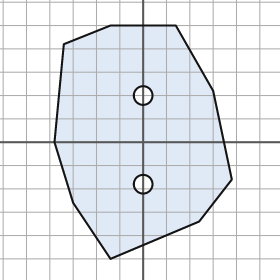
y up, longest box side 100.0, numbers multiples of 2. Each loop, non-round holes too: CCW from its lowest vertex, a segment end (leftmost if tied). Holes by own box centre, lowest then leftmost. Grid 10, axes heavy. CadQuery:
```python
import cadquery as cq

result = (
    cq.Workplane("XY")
    .moveTo(-14.0, -50.0)
    .lineTo(24.0, -34.0)
    .lineTo(38.0, -16.0)
    .lineTo(30.0, 22.0)
    .lineTo(14.0, 50.0)
    .lineTo(-14.0, 50.0)
    .lineTo(-34.0, 42.0)
    .lineTo(-38.0, 0.0)
    .lineTo(-30.0, -26.0)
    .close()
    .moveTo(0.0, -18.0)
    .circle(4.0)
    .moveTo(0.0, 20.0)
    .circle(4.0)
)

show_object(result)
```